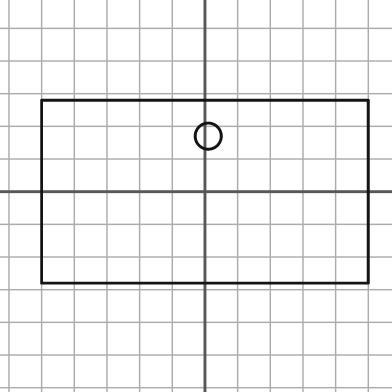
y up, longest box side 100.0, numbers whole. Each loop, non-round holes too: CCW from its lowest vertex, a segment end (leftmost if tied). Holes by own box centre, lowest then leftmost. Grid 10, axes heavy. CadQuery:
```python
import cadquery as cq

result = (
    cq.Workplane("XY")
    .moveTo(-50.0, -28.0)
    .lineTo(50.0, -28.0)
    .lineTo(50.0, 28.0)
    .lineTo(-50.0, 28.0)
    .close()
    .moveTo(1.0, 17.0)
    .circle(4.0)
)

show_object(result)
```